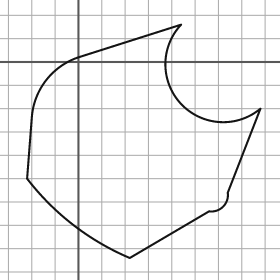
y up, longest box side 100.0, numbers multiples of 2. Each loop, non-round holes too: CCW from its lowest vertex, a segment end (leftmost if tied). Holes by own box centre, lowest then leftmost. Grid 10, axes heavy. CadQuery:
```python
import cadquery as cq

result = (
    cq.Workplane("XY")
    .moveTo(22.0, -84.0)
    .lineTo(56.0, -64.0)
    .threePointArc((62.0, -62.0), (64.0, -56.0))
    .lineTo(78.0, -20.0)
    .threePointArc((44.0, -18.0), (44.0, 16.0))
    .lineTo(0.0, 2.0)
    .threePointArc((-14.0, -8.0), (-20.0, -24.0))
    .lineTo(-22.0, -50.0)
    .threePointArc((-2.0, -70.0), (22.0, -84.0))
    .close()
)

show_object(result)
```